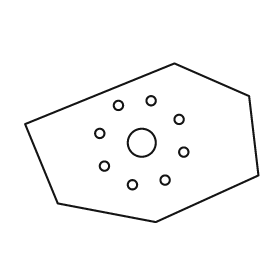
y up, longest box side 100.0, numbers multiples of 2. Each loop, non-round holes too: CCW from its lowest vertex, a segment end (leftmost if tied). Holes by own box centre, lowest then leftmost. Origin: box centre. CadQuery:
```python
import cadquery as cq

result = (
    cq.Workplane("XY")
    .moveTo(6.0, -34.0)
    .lineTo(50.0, -14.0)
    .lineTo(46.0, 20.0)
    .lineTo(14.0, 34.0)
    .lineTo(-50.0, 8.0)
    .lineTo(-36.0, -26.0)
    .close()
    .moveTo(-4.0, -18.0)
    .circle(2.0)
    .moveTo(10.0, -16.0)
    .circle(2.0)
    .moveTo(-16.0, -10.0)
    .circle(2.0)
    .moveTo(18.0, -4.0)
    .circle(2.0)
    .moveTo(0.0, 0.0)
    .circle(6.0)
    .moveTo(-18.0, 4.0)
    .circle(2.0)
    .moveTo(16.0, 10.0)
    .circle(2.0)
    .moveTo(-10.0, 16.0)
    .circle(2.0)
    .moveTo(4.0, 18.0)
    .circle(2.0)
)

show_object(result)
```